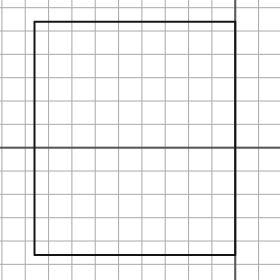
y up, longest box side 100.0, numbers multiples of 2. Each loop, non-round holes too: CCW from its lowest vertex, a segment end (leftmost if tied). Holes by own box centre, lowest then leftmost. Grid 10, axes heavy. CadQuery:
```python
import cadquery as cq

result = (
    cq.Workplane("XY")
    .moveTo(-86.0, -46.0)
    .lineTo(0.0, -46.0)
    .lineTo(0.0, 54.0)
    .lineTo(-86.0, 54.0)
    .close()
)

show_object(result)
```